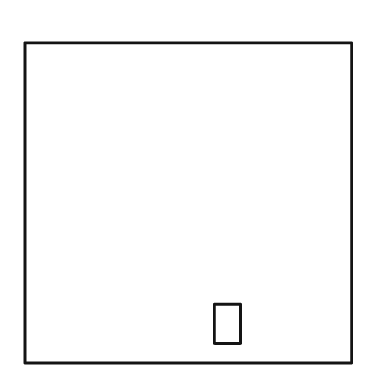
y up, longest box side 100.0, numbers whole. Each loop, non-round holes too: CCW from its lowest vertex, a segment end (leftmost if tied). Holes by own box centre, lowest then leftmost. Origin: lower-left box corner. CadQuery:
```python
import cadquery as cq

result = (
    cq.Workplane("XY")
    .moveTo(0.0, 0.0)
    .lineTo(100.0, 0.0)
    .lineTo(100.0, 98.0)
    .lineTo(0.0, 98.0)
    .close()
    .moveTo(58.0, 6.0)
    .lineTo(66.0, 6.0)
    .lineTo(66.0, 18.0)
    .lineTo(58.0, 18.0)
    .close()
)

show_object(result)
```